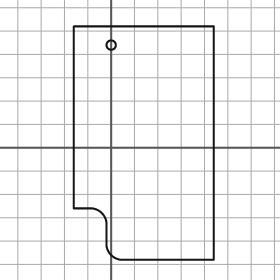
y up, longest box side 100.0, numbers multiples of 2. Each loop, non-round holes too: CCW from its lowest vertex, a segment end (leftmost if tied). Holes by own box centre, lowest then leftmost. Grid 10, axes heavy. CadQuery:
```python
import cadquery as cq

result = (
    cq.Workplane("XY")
    .moveTo(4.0, -48.0)
    .lineTo(44.0, -48.0)
    .lineTo(44.0, 52.0)
    .lineTo(-16.0, 52.0)
    .lineTo(-16.0, -26.0)
    .lineTo(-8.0, -26.0)
    .threePointArc((-4.0, -28.0), (-2.0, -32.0))
    .lineTo(-2.0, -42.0)
    .threePointArc((0.0, -46.0), (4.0, -48.0))
    .close()
    .moveTo(0.0, 44.0)
    .circle(2.0)
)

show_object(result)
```